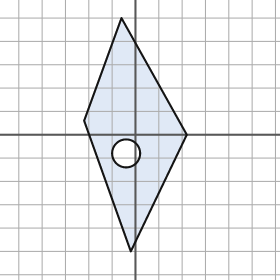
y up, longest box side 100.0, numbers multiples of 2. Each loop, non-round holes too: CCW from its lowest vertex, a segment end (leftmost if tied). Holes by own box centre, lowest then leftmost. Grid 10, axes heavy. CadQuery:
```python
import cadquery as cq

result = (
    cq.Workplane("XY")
    .moveTo(-2.0, -50.0)
    .lineTo(22.0, 0.0)
    .lineTo(-6.0, 50.0)
    .lineTo(-22.0, 6.0)
    .close()
    .moveTo(-4.0, -8.0)
    .circle(6.0)
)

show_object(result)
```